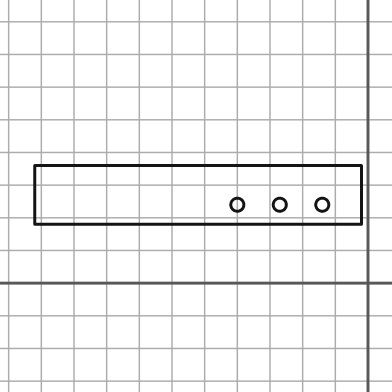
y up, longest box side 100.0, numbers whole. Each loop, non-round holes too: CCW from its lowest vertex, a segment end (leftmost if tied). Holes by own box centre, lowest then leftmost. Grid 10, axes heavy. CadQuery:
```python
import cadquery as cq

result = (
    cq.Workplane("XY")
    .moveTo(-102.0, 18.0)
    .lineTo(-2.0, 18.0)
    .lineTo(-2.0, 36.0)
    .lineTo(-102.0, 36.0)
    .close()
    .moveTo(-40.0, 24.0)
    .circle(2.0)
    .moveTo(-27.0, 24.0)
    .circle(2.0)
    .moveTo(-14.0, 24.0)
    .circle(2.0)
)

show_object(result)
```